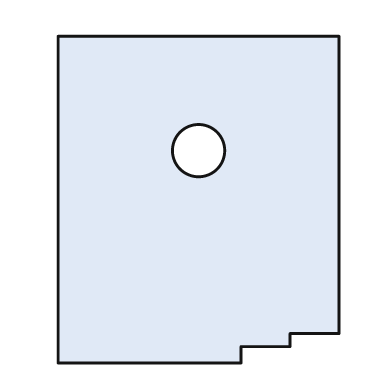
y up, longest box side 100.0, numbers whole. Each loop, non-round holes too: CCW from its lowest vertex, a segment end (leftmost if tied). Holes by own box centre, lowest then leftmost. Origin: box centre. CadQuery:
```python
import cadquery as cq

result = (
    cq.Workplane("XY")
    .moveTo(-43.0, -50.0)
    .lineTo(13.0, -50.0)
    .lineTo(13.0, -45.0)
    .lineTo(28.0, -45.0)
    .lineTo(28.0, -41.0)
    .lineTo(43.0, -41.0)
    .lineTo(43.0, 50.0)
    .lineTo(-43.0, 50.0)
    .close()
    .moveTo(0.0, 15.0)
    .circle(8.0)
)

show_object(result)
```